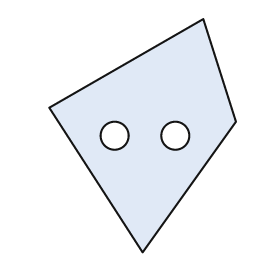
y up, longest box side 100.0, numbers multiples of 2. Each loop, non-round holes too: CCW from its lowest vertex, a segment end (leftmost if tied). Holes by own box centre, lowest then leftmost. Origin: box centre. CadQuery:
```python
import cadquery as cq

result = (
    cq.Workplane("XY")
    .moveTo(0.0, -50.0)
    .lineTo(40.0, 6.0)
    .lineTo(26.0, 50.0)
    .lineTo(-40.0, 12.0)
    .close()
    .moveTo(-12.0, 0.0)
    .circle(6.0)
    .moveTo(14.0, 0.0)
    .circle(6.0)
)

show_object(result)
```